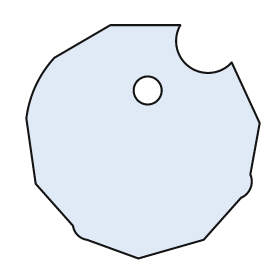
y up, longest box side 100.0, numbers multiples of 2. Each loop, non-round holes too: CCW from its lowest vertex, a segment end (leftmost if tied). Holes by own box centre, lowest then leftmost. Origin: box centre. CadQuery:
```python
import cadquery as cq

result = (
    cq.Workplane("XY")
    .moveTo(-2.0, -50.0)
    .lineTo(26.0, -42.0)
    .lineTo(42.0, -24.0)
    .threePointArc((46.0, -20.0), (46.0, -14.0))
    .lineTo(50.0, 8.0)
    .lineTo(38.0, 34.0)
    .threePointArc((20.0, 32.0), (16.0, 50.0))
    .lineTo(-14.0, 50.0)
    .lineTo(-38.0, 36.0)
    .threePointArc((-46.0, 24.0), (-50.0, 10.0))
    .lineTo(-46.0, -18.0)
    .lineTo(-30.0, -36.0)
    .threePointArc((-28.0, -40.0), (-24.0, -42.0))
    .close()
    .moveTo(2.0, 22.0)
    .circle(6.0)
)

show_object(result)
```